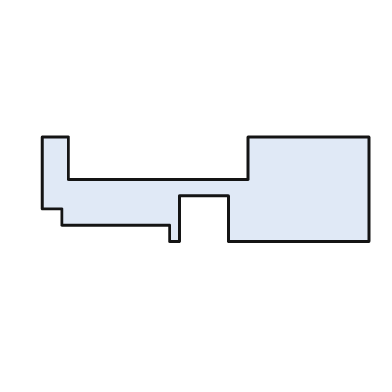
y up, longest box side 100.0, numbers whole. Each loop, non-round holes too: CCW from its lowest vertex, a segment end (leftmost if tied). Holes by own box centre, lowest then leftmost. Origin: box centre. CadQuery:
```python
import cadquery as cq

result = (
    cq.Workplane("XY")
    .moveTo(-11.0, -16.0)
    .lineTo(-8.0, -16.0)
    .lineTo(-8.0, -2.0)
    .lineTo(7.0, -2.0)
    .lineTo(7.0, -16.0)
    .lineTo(50.0, -16.0)
    .lineTo(50.0, 16.0)
    .lineTo(13.0, 16.0)
    .lineTo(13.0, 3.0)
    .lineTo(-42.0, 3.0)
    .lineTo(-42.0, 16.0)
    .lineTo(-50.0, 16.0)
    .lineTo(-50.0, -6.0)
    .lineTo(-44.0, -6.0)
    .lineTo(-44.0, -11.0)
    .lineTo(-11.0, -11.0)
    .close()
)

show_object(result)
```